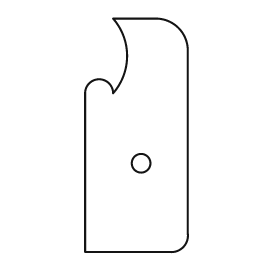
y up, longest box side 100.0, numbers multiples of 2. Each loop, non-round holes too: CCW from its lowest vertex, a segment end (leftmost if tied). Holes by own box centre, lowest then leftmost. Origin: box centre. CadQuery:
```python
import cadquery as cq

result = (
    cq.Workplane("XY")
    .moveTo(-22.0, -50.0)
    .lineTo(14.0, -50.0)
    .threePointArc((20.0, -48.0), (22.0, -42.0))
    .lineTo(22.0, 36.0)
    .threePointArc((18.0, 46.0), (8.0, 50.0))
    .lineTo(-10.0, 50.0)
    .threePointArc((-4.0, 34.0), (-10.0, 18.0))
    .threePointArc((-16.0, 24.0), (-22.0, 18.0))
    .close()
    .moveTo(2.0, -12.0)
    .circle(4.0)
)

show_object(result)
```